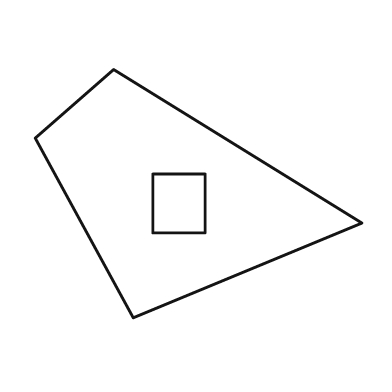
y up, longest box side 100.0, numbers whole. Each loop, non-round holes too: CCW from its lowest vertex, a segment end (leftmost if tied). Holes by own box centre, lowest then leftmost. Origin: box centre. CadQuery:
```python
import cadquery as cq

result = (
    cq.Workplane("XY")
    .moveTo(-20.0, -38.0)
    .lineTo(50.0, -9.0)
    .lineTo(-26.0, 38.0)
    .lineTo(-50.0, 17.0)
    .close()
    .moveTo(-14.0, -12.0)
    .lineTo(2.0, -12.0)
    .lineTo(2.0, 6.0)
    .lineTo(-14.0, 6.0)
    .close()
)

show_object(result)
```